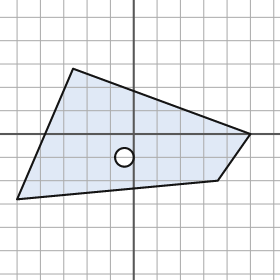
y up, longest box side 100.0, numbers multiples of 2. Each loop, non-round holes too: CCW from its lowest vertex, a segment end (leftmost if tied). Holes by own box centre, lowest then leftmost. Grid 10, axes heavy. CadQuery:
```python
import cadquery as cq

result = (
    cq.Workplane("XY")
    .moveTo(-50.0, -28.0)
    .lineTo(36.0, -20.0)
    .lineTo(50.0, 0.0)
    .lineTo(-26.0, 28.0)
    .close()
    .moveTo(-4.0, -10.0)
    .circle(4.0)
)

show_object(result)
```